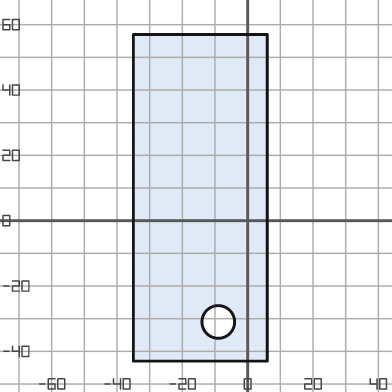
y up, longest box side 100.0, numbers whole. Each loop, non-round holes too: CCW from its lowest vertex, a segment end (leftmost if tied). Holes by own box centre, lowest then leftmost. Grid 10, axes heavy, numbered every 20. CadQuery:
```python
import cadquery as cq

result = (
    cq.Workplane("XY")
    .moveTo(-35.0, -43.0)
    .lineTo(6.0, -43.0)
    .lineTo(6.0, 57.0)
    .lineTo(-35.0, 57.0)
    .close()
    .moveTo(-9.0, -31.0)
    .circle(5.0)
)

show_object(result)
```